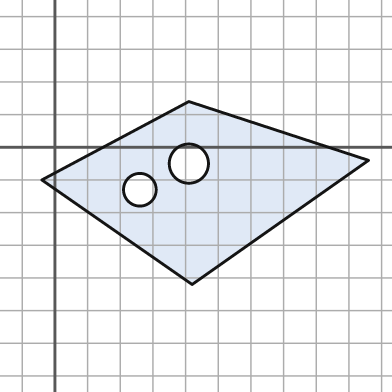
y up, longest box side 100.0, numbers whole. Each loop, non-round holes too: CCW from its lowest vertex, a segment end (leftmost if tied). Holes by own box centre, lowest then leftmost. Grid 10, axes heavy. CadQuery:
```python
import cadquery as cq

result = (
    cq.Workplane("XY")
    .moveTo(42.0, -42.0)
    .lineTo(96.0, -4.0)
    .lineTo(41.0, 14.0)
    .lineTo(-4.0, -10.0)
    .close()
    .moveTo(26.0, -13.0)
    .circle(5.0)
    .moveTo(41.0, -5.0)
    .circle(6.0)
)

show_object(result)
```